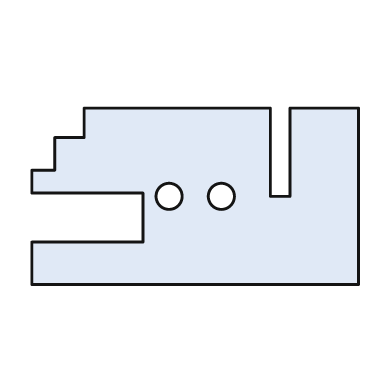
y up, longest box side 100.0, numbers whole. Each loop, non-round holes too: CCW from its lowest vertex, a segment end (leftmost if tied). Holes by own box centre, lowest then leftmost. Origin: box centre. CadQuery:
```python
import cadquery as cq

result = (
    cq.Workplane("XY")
    .moveTo(-50.0, -27.0)
    .lineTo(50.0, -27.0)
    .lineTo(50.0, 27.0)
    .lineTo(29.0, 27.0)
    .lineTo(29.0, 0.0)
    .lineTo(23.0, 0.0)
    .lineTo(23.0, 27.0)
    .lineTo(-34.0, 27.0)
    .lineTo(-34.0, 18.0)
    .lineTo(-43.0, 18.0)
    .lineTo(-43.0, 8.0)
    .lineTo(-50.0, 8.0)
    .lineTo(-50.0, 1.0)
    .lineTo(-16.0, 1.0)
    .lineTo(-16.0, -14.0)
    .lineTo(-50.0, -14.0)
    .close()
    .moveTo(-8.0, 0.0)
    .circle(4.0)
    .moveTo(8.0, 0.0)
    .circle(4.0)
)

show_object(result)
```